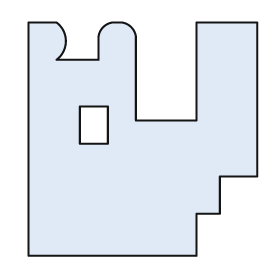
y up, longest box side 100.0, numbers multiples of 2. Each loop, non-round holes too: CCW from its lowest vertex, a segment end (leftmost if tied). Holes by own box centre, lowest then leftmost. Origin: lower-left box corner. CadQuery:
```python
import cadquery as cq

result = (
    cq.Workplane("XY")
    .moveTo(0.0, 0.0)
    .lineTo(72.0, 0.0)
    .lineTo(72.0, 18.0)
    .lineTo(82.0, 18.0)
    .lineTo(82.0, 34.0)
    .lineTo(98.0, 34.0)
    .lineTo(98.0, 100.0)
    .lineTo(72.0, 100.0)
    .lineTo(72.0, 58.0)
    .lineTo(46.0, 58.0)
    .lineTo(46.0, 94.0)
    .threePointArc((44.0, 98.0), (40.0, 100.0))
    .lineTo(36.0, 100.0)
    .threePointArc((32.0, 98.0), (30.0, 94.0))
    .lineTo(30.0, 84.0)
    .lineTo(12.0, 84.0)
    .threePointArc((16.0, 92.0), (12.0, 100.0))
    .lineTo(0.0, 100.0)
    .close()
    .moveTo(22.0, 48.0)
    .lineTo(34.0, 48.0)
    .lineTo(34.0, 64.0)
    .lineTo(22.0, 64.0)
    .close()
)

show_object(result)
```